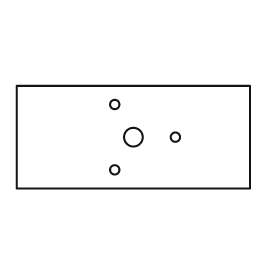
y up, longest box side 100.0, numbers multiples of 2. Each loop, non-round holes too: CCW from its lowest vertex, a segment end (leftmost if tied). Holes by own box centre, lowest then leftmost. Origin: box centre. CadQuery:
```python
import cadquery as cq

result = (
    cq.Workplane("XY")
    .moveTo(-50.0, -22.0)
    .lineTo(50.0, -22.0)
    .lineTo(50.0, 22.0)
    .lineTo(-50.0, 22.0)
    .close()
    .moveTo(-8.0, -14.0)
    .circle(2.0)
    .moveTo(0.0, 0.0)
    .circle(4.0)
    .moveTo(18.0, 0.0)
    .circle(2.0)
    .moveTo(-8.0, 14.0)
    .circle(2.0)
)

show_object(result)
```